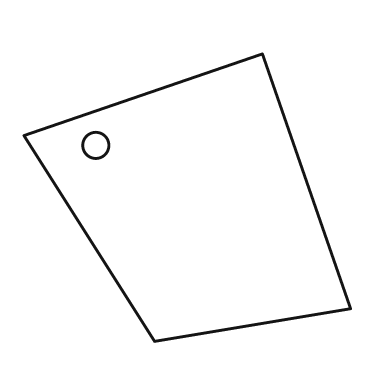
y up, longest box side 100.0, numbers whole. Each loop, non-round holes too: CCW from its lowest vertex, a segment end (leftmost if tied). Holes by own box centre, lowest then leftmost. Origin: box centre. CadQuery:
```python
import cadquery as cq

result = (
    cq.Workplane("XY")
    .moveTo(-10.0, -44.0)
    .lineTo(50.0, -34.0)
    .lineTo(23.0, 44.0)
    .lineTo(-50.0, 19.0)
    .close()
    .moveTo(-28.0, 16.0)
    .circle(4.0)
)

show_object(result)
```